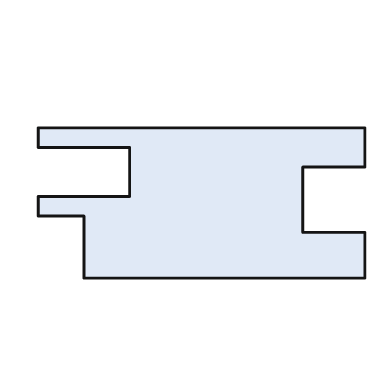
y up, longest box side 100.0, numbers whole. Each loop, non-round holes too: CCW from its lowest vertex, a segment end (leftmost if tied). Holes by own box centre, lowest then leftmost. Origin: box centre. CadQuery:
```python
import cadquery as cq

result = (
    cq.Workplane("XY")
    .moveTo(-36.0, -23.0)
    .lineTo(50.0, -23.0)
    .lineTo(50.0, -9.0)
    .lineTo(31.0, -9.0)
    .lineTo(31.0, 11.0)
    .lineTo(50.0, 11.0)
    .lineTo(50.0, 23.0)
    .lineTo(-50.0, 23.0)
    .lineTo(-50.0, 17.0)
    .lineTo(-22.0, 17.0)
    .lineTo(-22.0, 2.0)
    .lineTo(-50.0, 2.0)
    .lineTo(-50.0, -4.0)
    .lineTo(-36.0, -4.0)
    .close()
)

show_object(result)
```